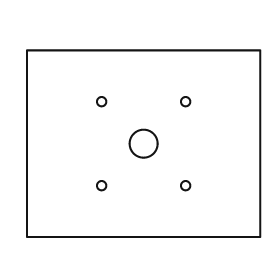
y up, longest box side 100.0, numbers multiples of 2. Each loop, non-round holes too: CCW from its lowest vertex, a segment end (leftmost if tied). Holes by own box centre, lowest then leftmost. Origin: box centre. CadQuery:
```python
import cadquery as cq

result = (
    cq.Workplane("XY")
    .moveTo(-50.0, -40.0)
    .lineTo(50.0, -40.0)
    .lineTo(50.0, 40.0)
    .lineTo(-50.0, 40.0)
    .close()
    .moveTo(-18.0, -18.0)
    .circle(2.0)
    .moveTo(18.0, -18.0)
    .circle(2.0)
    .moveTo(0.0, 0.0)
    .circle(6.0)
    .moveTo(-18.0, 18.0)
    .circle(2.0)
    .moveTo(18.0, 18.0)
    .circle(2.0)
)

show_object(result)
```